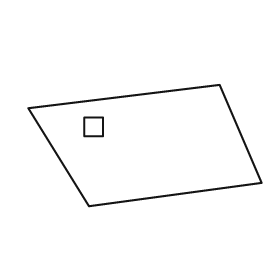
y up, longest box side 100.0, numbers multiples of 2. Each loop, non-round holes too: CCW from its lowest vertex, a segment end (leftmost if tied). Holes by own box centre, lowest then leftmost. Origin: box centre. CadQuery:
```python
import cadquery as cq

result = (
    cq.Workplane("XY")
    .moveTo(-24.0, -26.0)
    .lineTo(50.0, -16.0)
    .lineTo(32.0, 26.0)
    .lineTo(-50.0, 16.0)
    .close()
    .moveTo(-26.0, 4.0)
    .lineTo(-18.0, 4.0)
    .lineTo(-18.0, 12.0)
    .lineTo(-26.0, 12.0)
    .close()
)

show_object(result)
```